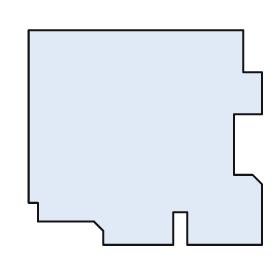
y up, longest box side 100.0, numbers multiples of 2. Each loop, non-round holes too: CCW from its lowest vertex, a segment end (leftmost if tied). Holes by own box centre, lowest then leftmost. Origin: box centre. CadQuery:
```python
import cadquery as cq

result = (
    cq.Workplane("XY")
    .moveTo(-18.0, -46.0)
    .lineTo(12.0, -46.0)
    .lineTo(12.0, -32.0)
    .lineTo(18.0, -32.0)
    .lineTo(18.0, -46.0)
    .lineTo(50.0, -46.0)
    .lineTo(50.0, -20.0)
    .lineTo(46.0, -16.0)
    .lineTo(38.0, -16.0)
    .lineTo(38.0, 10.0)
    .lineTo(50.0, 10.0)
    .lineTo(50.0, 28.0)
    .lineTo(42.0, 28.0)
    .lineTo(42.0, 46.0)
    .lineTo(-50.0, 46.0)
    .lineTo(-50.0, -28.0)
    .lineTo(-46.0, -28.0)
    .lineTo(-46.0, -36.0)
    .lineTo(-22.0, -36.0)
    .lineTo(-18.0, -40.0)
    .close()
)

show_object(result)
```